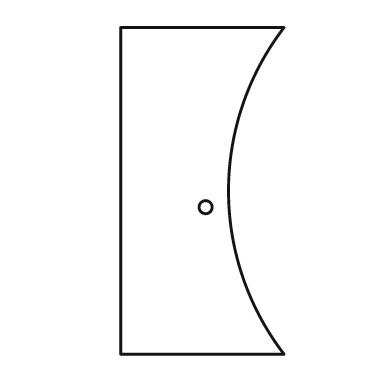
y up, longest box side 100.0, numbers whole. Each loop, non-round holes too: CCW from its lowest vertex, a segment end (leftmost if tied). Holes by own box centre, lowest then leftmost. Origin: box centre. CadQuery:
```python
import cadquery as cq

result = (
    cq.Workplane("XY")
    .moveTo(-25.0, -50.0)
    .lineTo(25.0, -50.0)
    .threePointArc((8.0, 0.0), (25.0, 50.0))
    .lineTo(-25.0, 50.0)
    .close()
    .moveTo(1.0, -5.0)
    .circle(2.0)
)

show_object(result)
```